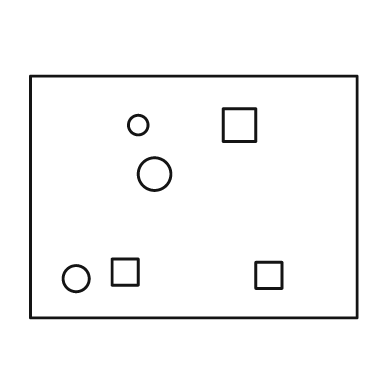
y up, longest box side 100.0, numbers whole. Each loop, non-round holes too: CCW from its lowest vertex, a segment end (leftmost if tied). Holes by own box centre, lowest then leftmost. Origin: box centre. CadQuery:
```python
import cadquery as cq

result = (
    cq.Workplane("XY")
    .moveTo(-50.0, -37.0)
    .lineTo(50.0, -37.0)
    .lineTo(50.0, 37.0)
    .lineTo(-50.0, 37.0)
    .close()
    .moveTo(-36.0, -25.0)
    .circle(4.0)
    .moveTo(19.0, -28.0)
    .lineTo(27.0, -28.0)
    .lineTo(27.0, -20.0)
    .lineTo(19.0, -20.0)
    .close()
    .moveTo(-25.0, -27.0)
    .lineTo(-17.0, -27.0)
    .lineTo(-17.0, -19.0)
    .lineTo(-25.0, -19.0)
    .close()
    .moveTo(-12.0, 7.0)
    .circle(5.0)
    .moveTo(-17.0, 22.0)
    .circle(3.0)
    .moveTo(9.0, 17.0)
    .lineTo(19.0, 17.0)
    .lineTo(19.0, 27.0)
    .lineTo(9.0, 27.0)
    .close()
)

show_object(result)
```